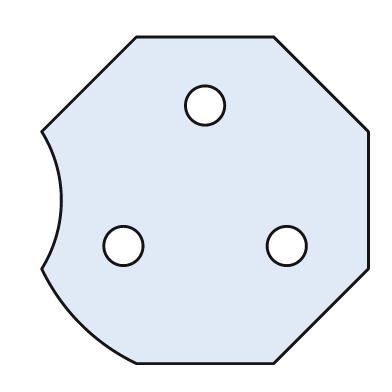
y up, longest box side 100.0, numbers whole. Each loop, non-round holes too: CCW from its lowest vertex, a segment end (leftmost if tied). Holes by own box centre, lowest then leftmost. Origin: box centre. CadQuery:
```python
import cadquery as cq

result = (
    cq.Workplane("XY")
    .moveTo(-21.0, -50.0)
    .lineTo(21.0, -50.0)
    .lineTo(50.0, -21.0)
    .lineTo(50.0, 21.0)
    .lineTo(21.0, 50.0)
    .lineTo(-21.0, 50.0)
    .lineTo(-50.0, 21.0)
    .threePointArc((-44.0, 0.0), (-50.0, -21.0))
    .threePointArc((-38.0, -38.0), (-21.0, -50.0))
    .close()
    .moveTo(-25.0, -14.0)
    .circle(6.0)
    .moveTo(25.0, -14.0)
    .circle(6.0)
    .moveTo(0.0, 29.0)
    .circle(6.0)
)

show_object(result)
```